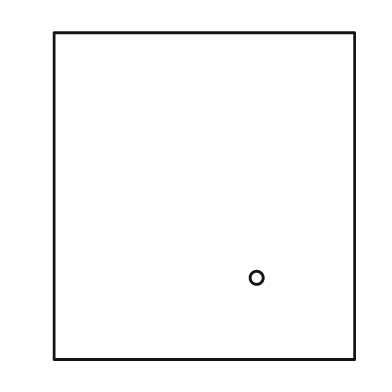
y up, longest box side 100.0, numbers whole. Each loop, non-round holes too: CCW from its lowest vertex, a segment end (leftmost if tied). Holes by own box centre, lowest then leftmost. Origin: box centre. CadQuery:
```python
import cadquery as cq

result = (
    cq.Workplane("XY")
    .moveTo(-46.0, -50.0)
    .lineTo(46.0, -50.0)
    .lineTo(46.0, 50.0)
    .lineTo(-46.0, 50.0)
    .close()
    .moveTo(16.0, -25.0)
    .circle(2.0)
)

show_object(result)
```